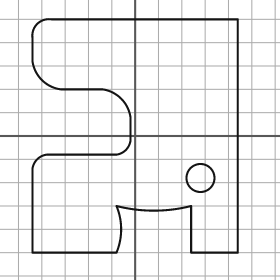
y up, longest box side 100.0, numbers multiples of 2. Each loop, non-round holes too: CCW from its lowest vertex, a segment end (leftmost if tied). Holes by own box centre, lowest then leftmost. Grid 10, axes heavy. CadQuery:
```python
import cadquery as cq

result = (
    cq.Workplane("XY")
    .moveTo(-44.0, -50.0)
    .lineTo(-8.0, -50.0)
    .threePointArc((-6.0, -40.0), (-8.0, -30.0))
    .threePointArc((8.0, -32.0), (24.0, -30.0))
    .lineTo(24.0, -50.0)
    .lineTo(44.0, -50.0)
    .lineTo(44.0, 50.0)
    .lineTo(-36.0, 50.0)
    .threePointArc((-42.0, 48.0), (-44.0, 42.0))
    .lineTo(-44.0, 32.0)
    .threePointArc((-40.0, 24.0), (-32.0, 20.0))
    .lineTo(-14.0, 20.0)
    .threePointArc((-6.0, 16.0), (-2.0, 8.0))
    .lineTo(-2.0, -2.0)
    .threePointArc((-4.0, -6.0), (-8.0, -8.0))
    .lineTo(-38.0, -8.0)
    .threePointArc((-42.0, -10.0), (-44.0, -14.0))
    .close()
    .moveTo(28.0, -18.0)
    .circle(6.0)
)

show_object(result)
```